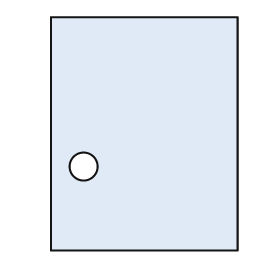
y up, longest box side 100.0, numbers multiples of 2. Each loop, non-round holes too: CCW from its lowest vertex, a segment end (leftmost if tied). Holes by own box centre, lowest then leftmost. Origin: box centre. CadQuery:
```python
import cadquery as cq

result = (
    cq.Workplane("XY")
    .moveTo(-40.0, -50.0)
    .lineTo(40.0, -50.0)
    .lineTo(40.0, 50.0)
    .lineTo(-40.0, 50.0)
    .close()
    .moveTo(-26.0, -14.0)
    .circle(6.0)
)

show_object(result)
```